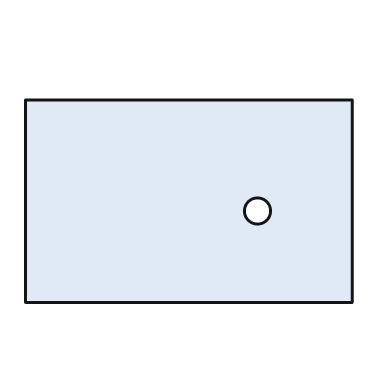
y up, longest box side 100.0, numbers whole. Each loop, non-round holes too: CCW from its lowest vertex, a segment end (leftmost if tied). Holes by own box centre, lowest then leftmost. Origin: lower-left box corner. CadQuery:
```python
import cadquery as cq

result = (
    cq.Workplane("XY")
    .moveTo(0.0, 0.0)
    .lineTo(100.0, 0.0)
    .lineTo(100.0, 62.0)
    .lineTo(0.0, 62.0)
    .close()
    .moveTo(71.0, 28.0)
    .circle(4.0)
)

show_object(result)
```